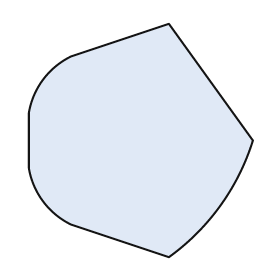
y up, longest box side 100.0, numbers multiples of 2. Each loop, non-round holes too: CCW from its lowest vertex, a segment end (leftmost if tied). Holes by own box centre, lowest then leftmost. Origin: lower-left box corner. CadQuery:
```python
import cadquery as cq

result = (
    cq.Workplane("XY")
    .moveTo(60.0, 0.0)
    .threePointArc((82.0, 22.0), (96.0, 50.0))
    .lineTo(60.0, 100.0)
    .lineTo(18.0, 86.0)
    .threePointArc((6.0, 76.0), (0.0, 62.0))
    .lineTo(0.0, 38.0)
    .threePointArc((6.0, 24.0), (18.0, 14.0))
    .close()
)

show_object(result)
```